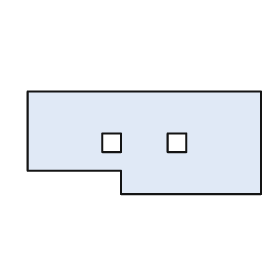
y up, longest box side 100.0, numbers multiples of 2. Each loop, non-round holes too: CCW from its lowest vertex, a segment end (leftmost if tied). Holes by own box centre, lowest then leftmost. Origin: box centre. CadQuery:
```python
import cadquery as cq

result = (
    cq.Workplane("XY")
    .moveTo(-10.0, -22.0)
    .lineTo(50.0, -22.0)
    .lineTo(50.0, 22.0)
    .lineTo(-50.0, 22.0)
    .lineTo(-50.0, -12.0)
    .lineTo(-10.0, -12.0)
    .close()
    .moveTo(-18.0, -4.0)
    .lineTo(-10.0, -4.0)
    .lineTo(-10.0, 4.0)
    .lineTo(-18.0, 4.0)
    .close()
    .moveTo(10.0, -4.0)
    .lineTo(18.0, -4.0)
    .lineTo(18.0, 4.0)
    .lineTo(10.0, 4.0)
    .close()
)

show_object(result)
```